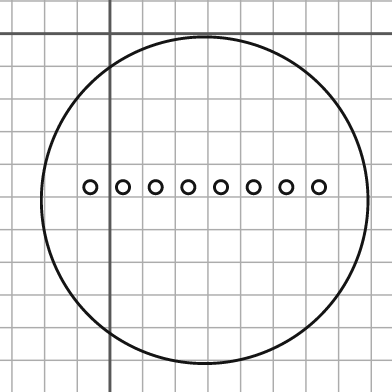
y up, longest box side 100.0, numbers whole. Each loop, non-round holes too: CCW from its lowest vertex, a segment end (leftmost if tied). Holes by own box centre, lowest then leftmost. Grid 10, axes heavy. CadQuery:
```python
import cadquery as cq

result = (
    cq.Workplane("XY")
    .moveTo(29.0, -51.0)
    .circle(50.0)
    .moveTo(-6.0, -47.0)
    .circle(2.0)
    .moveTo(4.0, -47.0)
    .circle(2.0)
    .moveTo(14.0, -47.0)
    .circle(2.0)
    .moveTo(24.0, -47.0)
    .circle(2.0)
    .moveTo(34.0, -47.0)
    .circle(2.0)
    .moveTo(44.0, -47.0)
    .circle(2.0)
    .moveTo(54.0, -47.0)
    .circle(2.0)
    .moveTo(64.0, -47.0)
    .circle(2.0)
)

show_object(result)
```